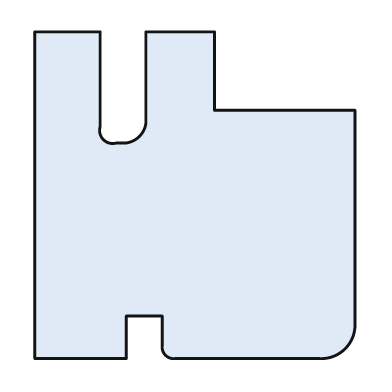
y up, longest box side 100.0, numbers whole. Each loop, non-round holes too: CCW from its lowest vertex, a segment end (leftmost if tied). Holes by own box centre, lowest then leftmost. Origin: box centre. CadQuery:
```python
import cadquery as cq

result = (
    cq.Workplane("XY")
    .moveTo(-49.0, -50.0)
    .lineTo(-21.0, -50.0)
    .lineTo(-21.0, -37.0)
    .lineTo(-10.0, -37.0)
    .lineTo(-10.0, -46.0)
    .threePointArc((-9.0, -49.0), (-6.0, -50.0))
    .lineTo(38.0, -50.0)
    .threePointArc((46.0, -47.0), (49.0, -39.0))
    .lineTo(49.0, 26.0)
    .lineTo(6.0, 26.0)
    .lineTo(6.0, 50.0)
    .lineTo(-15.0, 50.0)
    .lineTo(-15.0, 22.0)
    .threePointArc((-17.0, 18.0), (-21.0, 16.0))
    .lineTo(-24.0, 16.0)
    .threePointArc((-28.0, 17.0), (-29.0, 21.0))
    .lineTo(-29.0, 50.0)
    .lineTo(-49.0, 50.0)
    .close()
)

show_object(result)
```